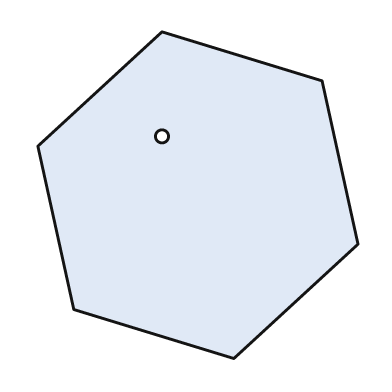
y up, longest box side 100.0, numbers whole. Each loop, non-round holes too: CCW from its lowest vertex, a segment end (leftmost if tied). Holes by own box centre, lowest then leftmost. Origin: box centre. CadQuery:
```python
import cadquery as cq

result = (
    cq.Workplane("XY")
    .moveTo(11.0, -50.0)
    .lineTo(49.0, -15.0)
    .lineTo(38.0, 35.0)
    .lineTo(-11.0, 50.0)
    .lineTo(-49.0, 15.0)
    .lineTo(-38.0, -35.0)
    .close()
    .moveTo(-11.0, 18.0)
    .circle(2.0)
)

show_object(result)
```